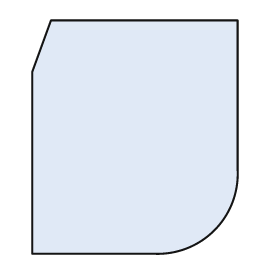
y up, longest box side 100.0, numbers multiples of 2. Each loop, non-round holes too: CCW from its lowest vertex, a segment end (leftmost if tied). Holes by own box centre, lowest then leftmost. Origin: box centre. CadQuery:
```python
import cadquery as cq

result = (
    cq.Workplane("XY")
    .moveTo(-44.0, -50.0)
    .lineTo(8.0, -50.0)
    .threePointArc((34.0, -40.0), (44.0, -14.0))
    .lineTo(44.0, 50.0)
    .lineTo(-36.0, 50.0)
    .lineTo(-44.0, 28.0)
    .close()
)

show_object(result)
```